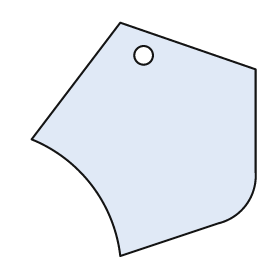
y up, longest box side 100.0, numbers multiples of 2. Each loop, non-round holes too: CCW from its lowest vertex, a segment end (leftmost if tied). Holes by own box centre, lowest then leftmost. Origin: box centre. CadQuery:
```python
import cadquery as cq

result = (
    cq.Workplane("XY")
    .moveTo(-10.0, -50.0)
    .lineTo(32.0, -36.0)
    .threePointArc((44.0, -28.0), (48.0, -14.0))
    .lineTo(48.0, 30.0)
    .lineTo(-10.0, 50.0)
    .lineTo(-48.0, 0.0)
    .threePointArc((-22.0, -20.0), (-10.0, -50.0))
    .close()
    .moveTo(0.0, 36.0)
    .circle(4.0)
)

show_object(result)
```